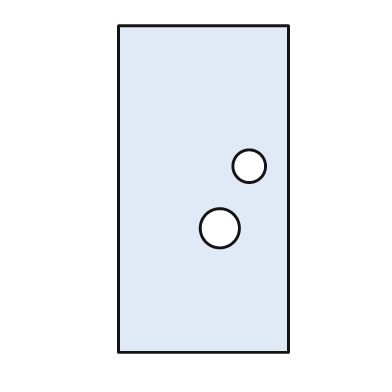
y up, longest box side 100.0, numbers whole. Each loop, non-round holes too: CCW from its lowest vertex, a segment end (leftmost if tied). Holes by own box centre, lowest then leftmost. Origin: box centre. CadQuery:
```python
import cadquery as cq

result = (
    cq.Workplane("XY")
    .moveTo(-26.0, -50.0)
    .lineTo(26.0, -50.0)
    .lineTo(26.0, 50.0)
    .lineTo(-26.0, 50.0)
    .close()
    .moveTo(5.0, -12.0)
    .circle(6.0)
    .moveTo(14.0, 7.0)
    .circle(5.0)
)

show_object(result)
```